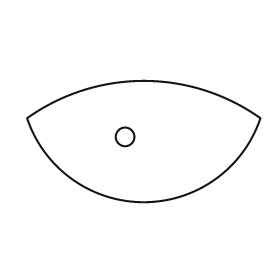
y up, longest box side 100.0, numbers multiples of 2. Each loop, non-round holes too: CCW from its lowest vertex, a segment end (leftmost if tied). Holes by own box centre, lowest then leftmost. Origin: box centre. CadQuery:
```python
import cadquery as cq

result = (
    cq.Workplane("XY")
    .moveTo(-50.0, 10.0)
    .threePointArc((0.0, -26.0), (50.0, 10.0))
    .threePointArc((0.0, 26.0), (-50.0, 10.0))
    .close()
    .moveTo(-8.0, 2.0)
    .circle(4.0)
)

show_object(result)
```